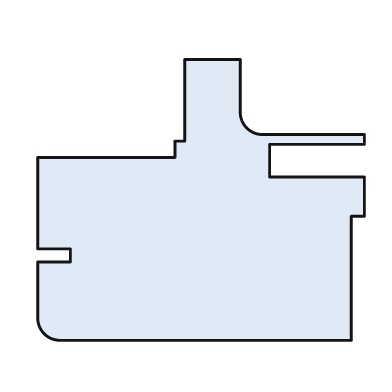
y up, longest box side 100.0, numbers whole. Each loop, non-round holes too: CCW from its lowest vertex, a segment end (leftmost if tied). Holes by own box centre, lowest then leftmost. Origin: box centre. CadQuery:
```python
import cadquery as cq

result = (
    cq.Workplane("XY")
    .moveTo(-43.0, -43.0)
    .lineTo(46.0, -43.0)
    .lineTo(46.0, -5.0)
    .lineTo(50.0, -5.0)
    .lineTo(50.0, 7.0)
    .lineTo(21.0, 7.0)
    .lineTo(21.0, 17.0)
    .lineTo(50.0, 17.0)
    .lineTo(50.0, 20.0)
    .lineTo(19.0, 20.0)
    .threePointArc((14.0, 22.0), (12.0, 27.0))
    .lineTo(12.0, 43.0)
    .lineTo(-5.0, 43.0)
    .lineTo(-5.0, 18.0)
    .lineTo(-8.0, 18.0)
    .lineTo(-8.0, 13.0)
    .lineTo(-50.0, 13.0)
    .lineTo(-50.0, -15.0)
    .lineTo(-40.0, -15.0)
    .lineTo(-40.0, -19.0)
    .lineTo(-50.0, -19.0)
    .lineTo(-50.0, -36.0)
    .threePointArc((-48.0, -41.0), (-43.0, -43.0))
    .close()
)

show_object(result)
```